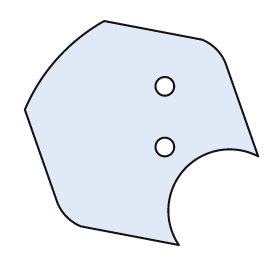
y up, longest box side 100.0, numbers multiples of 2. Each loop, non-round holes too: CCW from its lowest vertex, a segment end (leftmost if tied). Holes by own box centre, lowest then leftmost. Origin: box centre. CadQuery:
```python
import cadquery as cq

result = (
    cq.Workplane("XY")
    .moveTo(16.0, -48.0)
    .threePointArc((18.0, -16.0), (50.0, -10.0))
    .lineTo(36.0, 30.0)
    .threePointArc((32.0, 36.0), (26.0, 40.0))
    .lineTo(-16.0, 48.0)
    .threePointArc((-36.0, 32.0), (-50.0, 10.0))
    .lineTo(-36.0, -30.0)
    .threePointArc((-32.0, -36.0), (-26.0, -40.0))
    .close()
    .moveTo(10.0, -6.0)
    .circle(4.0)
    .moveTo(10.0, 20.0)
    .circle(4.0)
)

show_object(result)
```